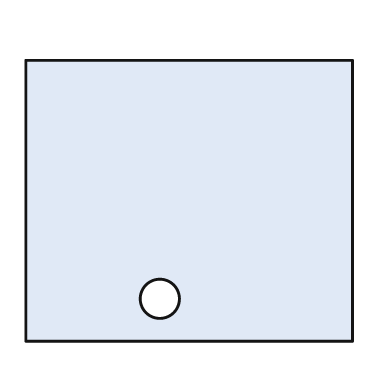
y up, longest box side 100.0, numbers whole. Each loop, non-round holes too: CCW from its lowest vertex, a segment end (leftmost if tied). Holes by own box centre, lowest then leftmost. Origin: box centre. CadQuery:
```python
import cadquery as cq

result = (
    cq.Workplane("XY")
    .moveTo(-50.0, -43.0)
    .lineTo(50.0, -43.0)
    .lineTo(50.0, 43.0)
    .lineTo(-50.0, 43.0)
    .close()
    .moveTo(-9.0, -30.0)
    .circle(6.0)
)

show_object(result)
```